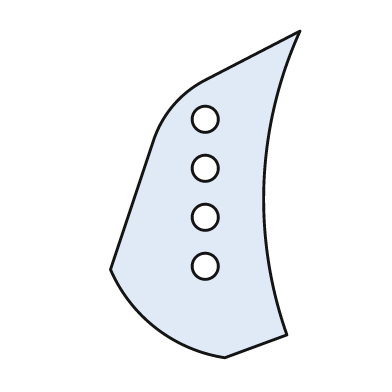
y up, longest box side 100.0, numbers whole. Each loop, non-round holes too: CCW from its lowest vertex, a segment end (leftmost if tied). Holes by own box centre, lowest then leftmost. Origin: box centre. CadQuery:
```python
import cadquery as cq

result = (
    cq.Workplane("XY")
    .moveTo(6.0, -50.0)
    .lineTo(25.0, -43.0)
    .threePointArc((18.0, 4.0), (29.0, 50.0))
    .lineTo(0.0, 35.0)
    .threePointArc((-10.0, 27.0), (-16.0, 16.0))
    .lineTo(-29.0, -23.0)
    .threePointArc((-15.0, -41.0), (6.0, -50.0))
    .close()
    .moveTo(0.0, -22.0)
    .circle(4.0)
    .moveTo(0.0, -7.0)
    .circle(4.0)
    .moveTo(0.0, 8.0)
    .circle(4.0)
    .moveTo(0.0, 23.0)
    .circle(4.0)
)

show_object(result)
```